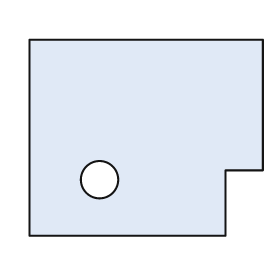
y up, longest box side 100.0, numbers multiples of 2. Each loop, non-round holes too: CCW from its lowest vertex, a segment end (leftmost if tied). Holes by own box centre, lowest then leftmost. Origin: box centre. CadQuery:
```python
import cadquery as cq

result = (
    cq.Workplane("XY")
    .moveTo(-50.0, -42.0)
    .lineTo(34.0, -42.0)
    .lineTo(34.0, -14.0)
    .lineTo(50.0, -14.0)
    .lineTo(50.0, 42.0)
    .lineTo(-50.0, 42.0)
    .close()
    .moveTo(-20.0, -18.0)
    .circle(8.0)
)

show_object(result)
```